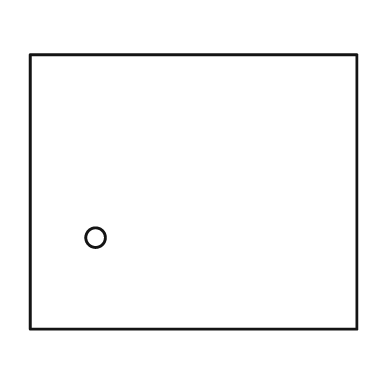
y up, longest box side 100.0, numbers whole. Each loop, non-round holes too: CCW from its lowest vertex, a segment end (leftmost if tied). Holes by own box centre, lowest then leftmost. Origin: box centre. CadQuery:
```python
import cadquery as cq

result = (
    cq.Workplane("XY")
    .moveTo(-50.0, -42.0)
    .lineTo(50.0, -42.0)
    .lineTo(50.0, 42.0)
    .lineTo(-50.0, 42.0)
    .close()
    .moveTo(-30.0, -14.0)
    .circle(3.0)
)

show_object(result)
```